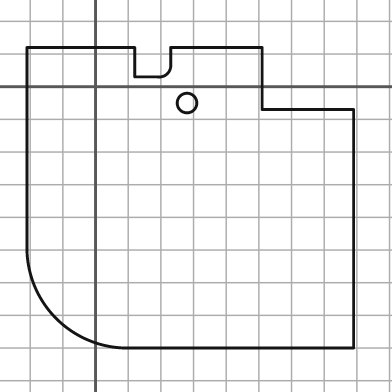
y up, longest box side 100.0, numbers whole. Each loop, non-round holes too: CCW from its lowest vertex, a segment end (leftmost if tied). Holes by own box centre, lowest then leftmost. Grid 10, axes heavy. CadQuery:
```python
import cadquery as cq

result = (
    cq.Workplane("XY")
    .moveTo(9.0, -80.0)
    .lineTo(79.0, -80.0)
    .lineTo(79.0, -7.0)
    .lineTo(51.0, -7.0)
    .lineTo(51.0, 12.0)
    .lineTo(23.0, 12.0)
    .lineTo(23.0, 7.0)
    .threePointArc((22.0, 4.0), (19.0, 3.0))
    .lineTo(12.0, 3.0)
    .lineTo(12.0, 12.0)
    .lineTo(-21.0, 12.0)
    .lineTo(-21.0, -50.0)
    .threePointArc((-12.0, -71.0), (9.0, -80.0))
    .close()
    .moveTo(28.0, -5.0)
    .circle(3.0)
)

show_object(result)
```